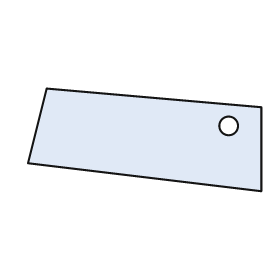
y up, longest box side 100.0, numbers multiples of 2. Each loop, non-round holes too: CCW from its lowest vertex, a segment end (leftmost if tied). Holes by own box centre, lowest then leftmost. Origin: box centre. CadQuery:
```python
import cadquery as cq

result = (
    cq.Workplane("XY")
    .moveTo(50.0, -22.0)
    .lineTo(50.0, 14.0)
    .lineTo(-42.0, 22.0)
    .lineTo(-50.0, -10.0)
    .close()
    .moveTo(36.0, 6.0)
    .circle(4.0)
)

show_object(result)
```